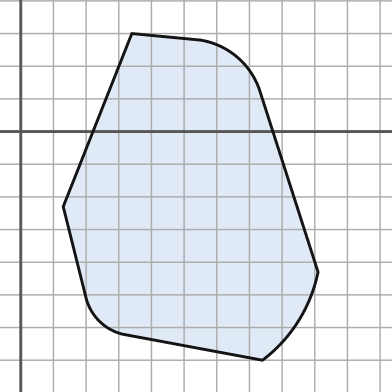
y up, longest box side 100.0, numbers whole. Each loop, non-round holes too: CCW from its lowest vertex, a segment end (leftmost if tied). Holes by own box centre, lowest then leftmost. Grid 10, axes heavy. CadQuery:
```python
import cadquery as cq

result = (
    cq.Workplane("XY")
    .moveTo(74.0, -70.0)
    .threePointArc((85.0, -58.0), (91.0, -43.0))
    .lineTo(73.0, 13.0)
    .threePointArc((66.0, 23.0), (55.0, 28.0))
    .lineTo(34.0, 30.0)
    .lineTo(13.0, -23.0)
    .lineTo(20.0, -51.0)
    .threePointArc((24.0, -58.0), (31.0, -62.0))
    .close()
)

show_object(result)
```